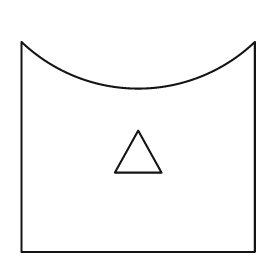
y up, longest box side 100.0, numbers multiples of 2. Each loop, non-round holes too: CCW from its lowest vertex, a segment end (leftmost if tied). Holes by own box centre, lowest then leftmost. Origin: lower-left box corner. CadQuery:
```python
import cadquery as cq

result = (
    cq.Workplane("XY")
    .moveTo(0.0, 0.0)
    .lineTo(100.0, 0.0)
    .lineTo(100.0, 90.0)
    .threePointArc((50.0, 70.0), (0.0, 90.0))
    .close()
    .moveTo(40.0, 34.0)
    .lineTo(60.0, 34.0)
    .lineTo(50.0, 52.0)
    .close()
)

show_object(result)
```